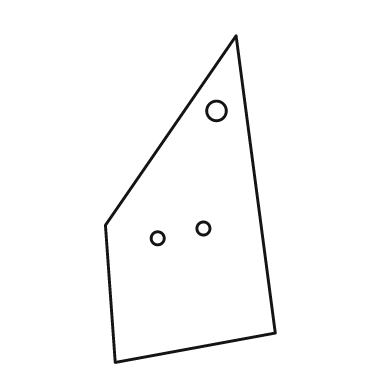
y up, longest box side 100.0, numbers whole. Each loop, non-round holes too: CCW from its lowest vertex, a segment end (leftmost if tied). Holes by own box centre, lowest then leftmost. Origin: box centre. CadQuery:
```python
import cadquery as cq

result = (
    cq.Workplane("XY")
    .moveTo(-23.0, -50.0)
    .lineTo(26.0, -41.0)
    .lineTo(14.0, 50.0)
    .lineTo(-26.0, -8.0)
    .close()
    .moveTo(-10.0, -12.0)
    .circle(2.0)
    .moveTo(4.0, -9.0)
    .circle(2.0)
    .moveTo(8.0, 27.0)
    .circle(3.0)
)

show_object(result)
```